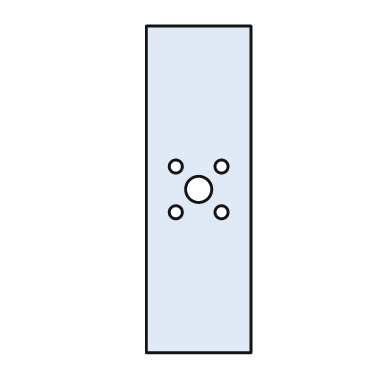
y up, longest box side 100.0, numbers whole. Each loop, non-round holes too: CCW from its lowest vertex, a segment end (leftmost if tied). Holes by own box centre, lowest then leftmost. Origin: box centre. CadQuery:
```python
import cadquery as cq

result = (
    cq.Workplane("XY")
    .moveTo(-16.0, -50.0)
    .lineTo(16.0, -50.0)
    .lineTo(16.0, 50.0)
    .lineTo(-16.0, 50.0)
    .close()
    .moveTo(-7.0, -7.0)
    .circle(2.0)
    .moveTo(7.0, -7.0)
    .circle(2.0)
    .moveTo(0.0, 0.0)
    .circle(4.0)
    .moveTo(-7.0, 7.0)
    .circle(2.0)
    .moveTo(7.0, 7.0)
    .circle(2.0)
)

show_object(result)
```